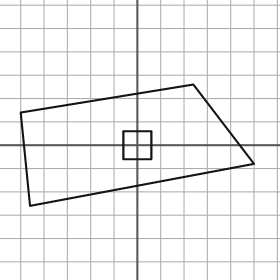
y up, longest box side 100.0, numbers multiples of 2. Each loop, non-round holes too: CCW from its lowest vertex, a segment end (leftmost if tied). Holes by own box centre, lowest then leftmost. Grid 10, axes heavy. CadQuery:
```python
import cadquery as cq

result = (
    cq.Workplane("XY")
    .moveTo(-46.0, -26.0)
    .lineTo(50.0, -8.0)
    .lineTo(24.0, 26.0)
    .lineTo(-50.0, 14.0)
    .close()
    .moveTo(-6.0, -6.0)
    .lineTo(6.0, -6.0)
    .lineTo(6.0, 6.0)
    .lineTo(-6.0, 6.0)
    .close()
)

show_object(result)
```